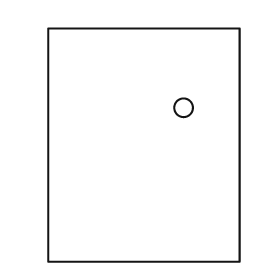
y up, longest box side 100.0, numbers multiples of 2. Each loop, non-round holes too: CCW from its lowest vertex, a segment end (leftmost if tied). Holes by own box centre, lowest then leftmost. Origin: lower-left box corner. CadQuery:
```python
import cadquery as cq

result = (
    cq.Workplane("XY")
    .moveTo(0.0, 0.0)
    .lineTo(82.0, 0.0)
    .lineTo(82.0, 100.0)
    .lineTo(0.0, 100.0)
    .close()
    .moveTo(58.0, 66.0)
    .circle(4.0)
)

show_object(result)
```